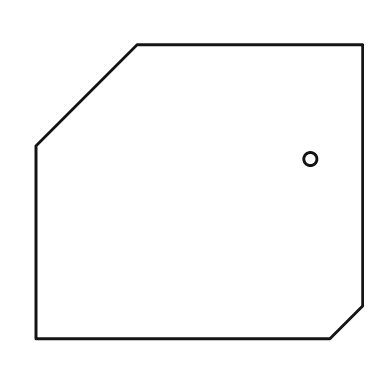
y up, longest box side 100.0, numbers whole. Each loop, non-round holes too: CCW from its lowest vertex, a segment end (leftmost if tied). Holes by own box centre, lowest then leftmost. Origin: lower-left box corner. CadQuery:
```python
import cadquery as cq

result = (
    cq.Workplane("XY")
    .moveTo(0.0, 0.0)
    .lineTo(90.0, 0.0)
    .lineTo(100.0, 10.0)
    .lineTo(100.0, 90.0)
    .lineTo(31.0, 90.0)
    .lineTo(0.0, 59.0)
    .close()
    .moveTo(84.0, 55.0)
    .circle(2.0)
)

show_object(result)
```